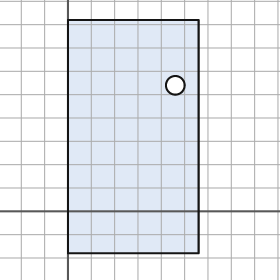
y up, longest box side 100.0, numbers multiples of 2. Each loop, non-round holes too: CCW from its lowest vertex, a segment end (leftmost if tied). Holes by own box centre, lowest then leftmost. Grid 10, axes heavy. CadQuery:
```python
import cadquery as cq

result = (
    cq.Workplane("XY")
    .moveTo(0.0, -18.0)
    .lineTo(56.0, -18.0)
    .lineTo(56.0, 82.0)
    .lineTo(0.0, 82.0)
    .close()
    .moveTo(46.0, 54.0)
    .circle(4.0)
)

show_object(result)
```